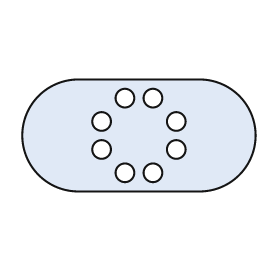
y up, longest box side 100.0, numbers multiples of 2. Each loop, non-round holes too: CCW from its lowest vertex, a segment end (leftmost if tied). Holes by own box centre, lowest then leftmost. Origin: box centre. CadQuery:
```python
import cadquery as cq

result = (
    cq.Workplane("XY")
    .moveTo(-26.0, -24.0)
    .lineTo(26.0, -24.0)
    .threePointArc((50.0, 0.0), (26.0, 24.0))
    .lineTo(-26.0, 24.0)
    .threePointArc((-50.0, 0.0), (-26.0, -24.0))
    .close()
    .moveTo(-6.0, -16.0)
    .circle(4.0)
    .moveTo(6.0, -16.0)
    .circle(4.0)
    .moveTo(-16.0, -6.0)
    .circle(4.0)
    .moveTo(16.0, -6.0)
    .circle(4.0)
    .moveTo(-16.0, 6.0)
    .circle(4.0)
    .moveTo(16.0, 6.0)
    .circle(4.0)
    .moveTo(-6.0, 16.0)
    .circle(4.0)
    .moveTo(6.0, 16.0)
    .circle(4.0)
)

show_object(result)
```